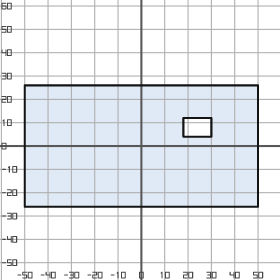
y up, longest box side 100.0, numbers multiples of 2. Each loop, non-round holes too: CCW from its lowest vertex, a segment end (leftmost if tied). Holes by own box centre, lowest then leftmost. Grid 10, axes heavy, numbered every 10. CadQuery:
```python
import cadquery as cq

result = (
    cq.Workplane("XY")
    .moveTo(-50.0, -26.0)
    .lineTo(50.0, -26.0)
    .lineTo(50.0, 26.0)
    .lineTo(-50.0, 26.0)
    .close()
    .moveTo(18.0, 4.0)
    .lineTo(30.0, 4.0)
    .lineTo(30.0, 12.0)
    .lineTo(18.0, 12.0)
    .close()
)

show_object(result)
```